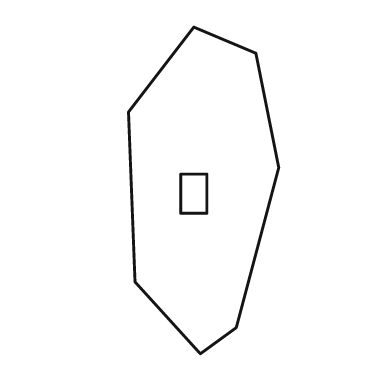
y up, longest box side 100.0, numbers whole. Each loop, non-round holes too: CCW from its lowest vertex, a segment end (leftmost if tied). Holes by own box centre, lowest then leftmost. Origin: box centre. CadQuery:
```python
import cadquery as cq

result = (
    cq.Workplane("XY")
    .moveTo(-1.0, -50.0)
    .lineTo(10.0, -42.0)
    .lineTo(23.0, 7.0)
    .lineTo(16.0, 42.0)
    .lineTo(-3.0, 50.0)
    .lineTo(-23.0, 24.0)
    .lineTo(-21.0, -28.0)
    .close()
    .moveTo(-7.0, -7.0)
    .lineTo(1.0, -7.0)
    .lineTo(1.0, 5.0)
    .lineTo(-7.0, 5.0)
    .close()
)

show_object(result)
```